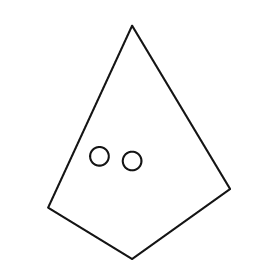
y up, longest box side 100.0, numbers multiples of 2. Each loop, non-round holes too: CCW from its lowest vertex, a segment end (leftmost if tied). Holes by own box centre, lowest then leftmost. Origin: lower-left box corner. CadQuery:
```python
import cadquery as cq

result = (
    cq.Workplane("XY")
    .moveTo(36.0, 0.0)
    .lineTo(78.0, 30.0)
    .lineTo(36.0, 100.0)
    .lineTo(0.0, 22.0)
    .close()
    .moveTo(36.0, 42.0)
    .circle(4.0)
    .moveTo(22.0, 44.0)
    .circle(4.0)
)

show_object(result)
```